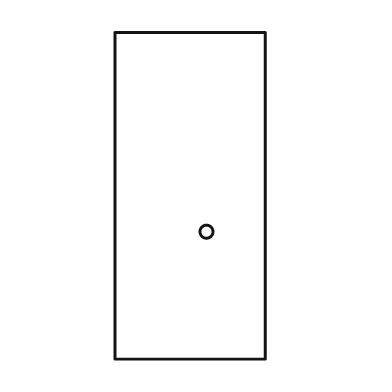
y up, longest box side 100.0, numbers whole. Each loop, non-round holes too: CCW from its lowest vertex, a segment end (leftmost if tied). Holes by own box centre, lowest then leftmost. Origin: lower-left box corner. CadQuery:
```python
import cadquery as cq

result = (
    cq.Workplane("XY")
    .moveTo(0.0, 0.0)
    .lineTo(46.0, 0.0)
    .lineTo(46.0, 100.0)
    .lineTo(0.0, 100.0)
    .close()
    .moveTo(28.0, 39.0)
    .circle(2.0)
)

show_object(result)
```